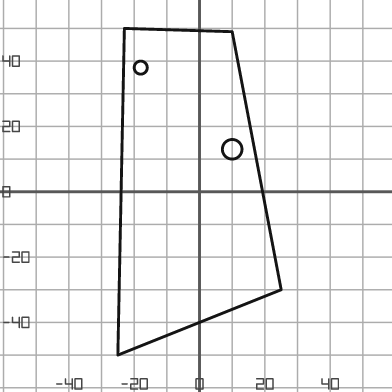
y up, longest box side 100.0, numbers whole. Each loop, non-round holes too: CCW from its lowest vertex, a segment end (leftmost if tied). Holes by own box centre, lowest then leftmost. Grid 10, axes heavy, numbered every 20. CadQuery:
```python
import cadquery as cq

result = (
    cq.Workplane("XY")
    .moveTo(-25.0, -50.0)
    .lineTo(25.0, -30.0)
    .lineTo(10.0, 49.0)
    .lineTo(-23.0, 50.0)
    .close()
    .moveTo(10.0, 13.0)
    .circle(3.0)
    .moveTo(-18.0, 38.0)
    .circle(2.0)
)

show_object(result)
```